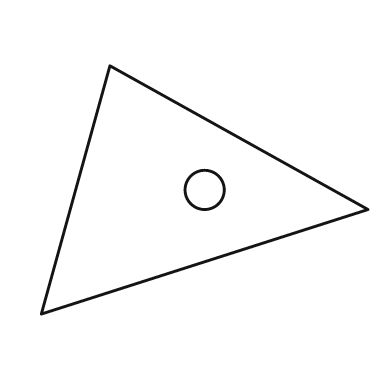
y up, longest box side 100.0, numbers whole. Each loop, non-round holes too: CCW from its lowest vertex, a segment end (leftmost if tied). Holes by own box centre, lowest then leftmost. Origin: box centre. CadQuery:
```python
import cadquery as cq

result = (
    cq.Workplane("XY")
    .moveTo(-50.0, -38.0)
    .lineTo(50.0, -6.0)
    .lineTo(-29.0, 38.0)
    .close()
    .moveTo(0.0, 0.0)
    .circle(6.0)
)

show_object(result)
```